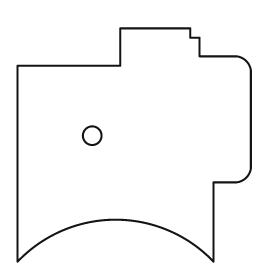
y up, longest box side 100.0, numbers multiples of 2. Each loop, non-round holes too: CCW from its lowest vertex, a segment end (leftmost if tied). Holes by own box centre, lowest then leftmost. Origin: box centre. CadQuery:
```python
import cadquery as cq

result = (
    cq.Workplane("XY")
    .moveTo(-50.0, -50.0)
    .threePointArc((-8.0, -32.0), (34.0, -50.0))
    .lineTo(34.0, -16.0)
    .lineTo(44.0, -16.0)
    .threePointArc((48.0, -14.0), (50.0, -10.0))
    .lineTo(50.0, 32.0)
    .threePointArc((48.0, 36.0), (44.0, 38.0))
    .lineTo(28.0, 38.0)
    .lineTo(28.0, 46.0)
    .lineTo(24.0, 46.0)
    .lineTo(24.0, 50.0)
    .lineTo(-6.0, 50.0)
    .lineTo(-6.0, 34.0)
    .lineTo(-50.0, 34.0)
    .close()
    .moveTo(-18.0, 4.0)
    .circle(4.0)
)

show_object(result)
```